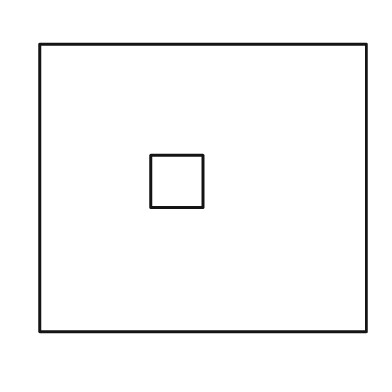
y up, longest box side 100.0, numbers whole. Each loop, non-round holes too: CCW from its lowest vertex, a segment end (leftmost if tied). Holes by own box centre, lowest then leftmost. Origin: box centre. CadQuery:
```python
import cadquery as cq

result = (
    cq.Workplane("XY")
    .moveTo(-50.0, -44.0)
    .lineTo(50.0, -44.0)
    .lineTo(50.0, 44.0)
    .lineTo(-50.0, 44.0)
    .close()
    .moveTo(-16.0, -6.0)
    .lineTo(0.0, -6.0)
    .lineTo(0.0, 10.0)
    .lineTo(-16.0, 10.0)
    .close()
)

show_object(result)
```